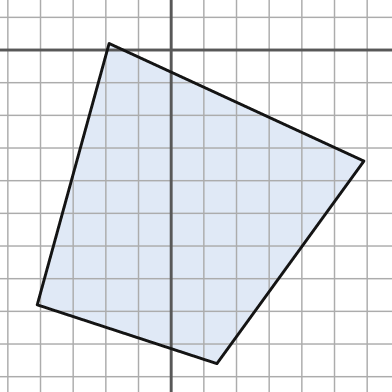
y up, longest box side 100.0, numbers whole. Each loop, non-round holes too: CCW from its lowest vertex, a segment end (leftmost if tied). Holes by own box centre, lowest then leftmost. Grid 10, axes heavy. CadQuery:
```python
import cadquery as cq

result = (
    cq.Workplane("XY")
    .moveTo(14.0, -96.0)
    .lineTo(59.0, -34.0)
    .lineTo(-19.0, 2.0)
    .lineTo(-41.0, -78.0)
    .close()
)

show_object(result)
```